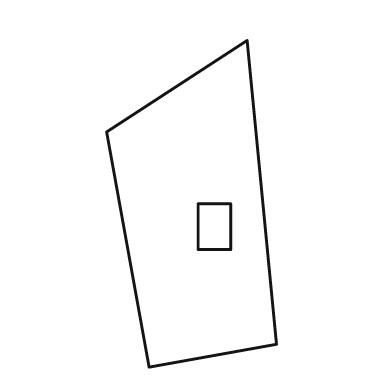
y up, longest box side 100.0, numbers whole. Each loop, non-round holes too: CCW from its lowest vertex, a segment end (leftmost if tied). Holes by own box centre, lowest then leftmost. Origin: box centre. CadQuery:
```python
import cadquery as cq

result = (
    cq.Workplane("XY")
    .moveTo(-13.0, -50.0)
    .lineTo(26.0, -43.0)
    .lineTo(17.0, 50.0)
    .lineTo(-26.0, 22.0)
    .close()
    .moveTo(2.0, -14.0)
    .lineTo(12.0, -14.0)
    .lineTo(12.0, 0.0)
    .lineTo(2.0, 0.0)
    .close()
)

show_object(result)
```